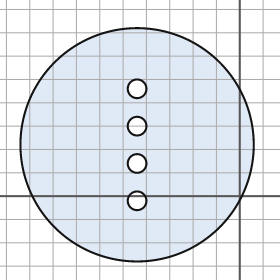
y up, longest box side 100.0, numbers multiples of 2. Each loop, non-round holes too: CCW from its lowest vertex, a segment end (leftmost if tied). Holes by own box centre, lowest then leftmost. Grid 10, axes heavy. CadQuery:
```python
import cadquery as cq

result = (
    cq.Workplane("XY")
    .moveTo(-44.0, 22.0)
    .circle(50.0)
    .moveTo(-44.0, -2.0)
    .circle(4.0)
    .moveTo(-44.0, 14.0)
    .circle(4.0)
    .moveTo(-44.0, 30.0)
    .circle(4.0)
    .moveTo(-44.0, 46.0)
    .circle(4.0)
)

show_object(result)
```